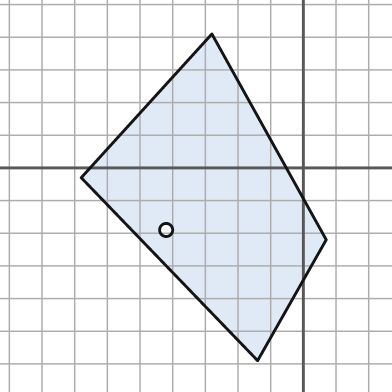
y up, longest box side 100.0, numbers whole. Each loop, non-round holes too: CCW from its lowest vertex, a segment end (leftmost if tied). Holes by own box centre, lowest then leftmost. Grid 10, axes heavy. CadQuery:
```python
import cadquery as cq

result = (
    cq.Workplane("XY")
    .moveTo(-14.0, -59.0)
    .lineTo(7.0, -22.0)
    .lineTo(-28.0, 41.0)
    .lineTo(-68.0, -3.0)
    .close()
    .moveTo(-42.0, -19.0)
    .circle(2.0)
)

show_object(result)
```